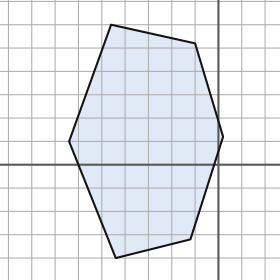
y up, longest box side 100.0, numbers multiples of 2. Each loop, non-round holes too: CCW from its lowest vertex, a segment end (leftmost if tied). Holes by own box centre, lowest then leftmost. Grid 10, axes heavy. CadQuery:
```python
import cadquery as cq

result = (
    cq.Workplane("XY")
    .moveTo(-44.0, -40.0)
    .lineTo(-12.0, -32.0)
    .lineTo(2.0, 12.0)
    .lineTo(-10.0, 52.0)
    .lineTo(-46.0, 60.0)
    .lineTo(-64.0, 10.0)
    .close()
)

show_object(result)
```